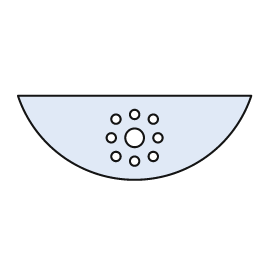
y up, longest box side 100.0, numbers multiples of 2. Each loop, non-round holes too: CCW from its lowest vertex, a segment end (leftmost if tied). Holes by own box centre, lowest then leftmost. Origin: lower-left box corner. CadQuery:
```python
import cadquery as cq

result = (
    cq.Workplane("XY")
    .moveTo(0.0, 36.0)
    .threePointArc((50.0, 0.0), (100.0, 36.0))
    .close()
    .moveTo(50.0, 8.0)
    .circle(2.0)
    .moveTo(42.0, 10.0)
    .circle(2.0)
    .moveTo(58.0, 10.0)
    .circle(2.0)
    .moveTo(40.0, 18.0)
    .circle(2.0)
    .moveTo(50.0, 18.0)
    .circle(4.0)
    .moveTo(60.0, 18.0)
    .circle(2.0)
    .moveTo(42.0, 26.0)
    .circle(2.0)
    .moveTo(58.0, 26.0)
    .circle(2.0)
    .moveTo(50.0, 28.0)
    .circle(2.0)
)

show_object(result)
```